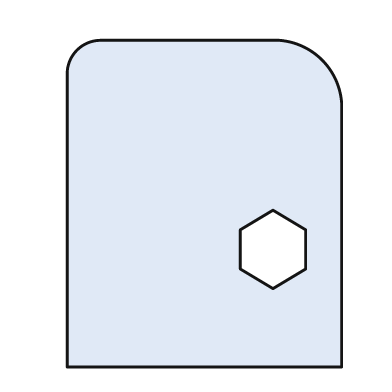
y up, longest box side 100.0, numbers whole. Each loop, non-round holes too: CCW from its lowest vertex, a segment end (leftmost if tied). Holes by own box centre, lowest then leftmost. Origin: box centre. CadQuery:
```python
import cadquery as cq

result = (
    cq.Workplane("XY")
    .moveTo(-42.0, -50.0)
    .lineTo(42.0, -50.0)
    .lineTo(42.0, 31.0)
    .threePointArc((36.0, 44.0), (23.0, 50.0))
    .lineTo(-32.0, 50.0)
    .threePointArc((-39.0, 47.0), (-42.0, 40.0))
    .close()
    .moveTo(21.0, -26.0)
    .lineTo(31.0, -20.0)
    .lineTo(31.0, -8.0)
    .lineTo(21.0, -2.0)
    .lineTo(11.0, -8.0)
    .lineTo(11.0, -20.0)
    .close()
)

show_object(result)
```